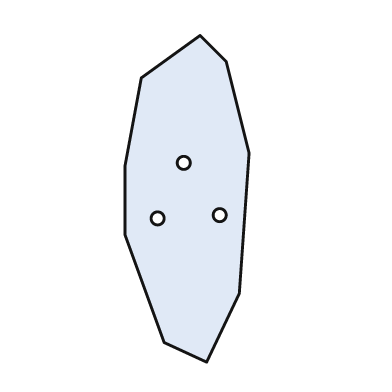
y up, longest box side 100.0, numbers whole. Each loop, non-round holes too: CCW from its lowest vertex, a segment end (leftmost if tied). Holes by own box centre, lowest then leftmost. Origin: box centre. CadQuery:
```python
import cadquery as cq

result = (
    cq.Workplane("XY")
    .moveTo(6.0, -50.0)
    .lineTo(16.0, -29.0)
    .lineTo(19.0, 14.0)
    .lineTo(12.0, 42.0)
    .lineTo(4.0, 50.0)
    .lineTo(-14.0, 37.0)
    .lineTo(-19.0, 10.0)
    .lineTo(-19.0, -11.0)
    .lineTo(-7.0, -44.0)
    .close()
    .moveTo(-9.0, -6.0)
    .circle(2.0)
    .moveTo(10.0, -5.0)
    .circle(2.0)
    .moveTo(-1.0, 11.0)
    .circle(2.0)
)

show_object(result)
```